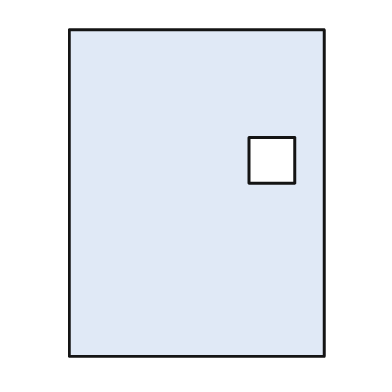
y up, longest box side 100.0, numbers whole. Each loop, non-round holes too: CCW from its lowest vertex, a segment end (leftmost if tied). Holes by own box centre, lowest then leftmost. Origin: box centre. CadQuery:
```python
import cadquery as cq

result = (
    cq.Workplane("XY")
    .moveTo(-39.0, -50.0)
    .lineTo(39.0, -50.0)
    .lineTo(39.0, 50.0)
    .lineTo(-39.0, 50.0)
    .close()
    .moveTo(16.0, 3.0)
    .lineTo(30.0, 3.0)
    .lineTo(30.0, 17.0)
    .lineTo(16.0, 17.0)
    .close()
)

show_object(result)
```